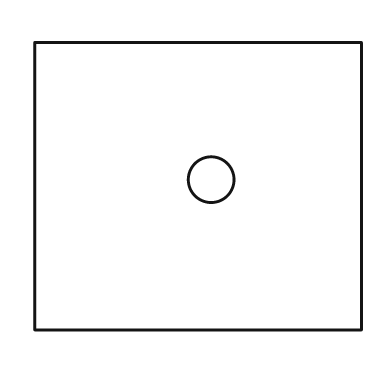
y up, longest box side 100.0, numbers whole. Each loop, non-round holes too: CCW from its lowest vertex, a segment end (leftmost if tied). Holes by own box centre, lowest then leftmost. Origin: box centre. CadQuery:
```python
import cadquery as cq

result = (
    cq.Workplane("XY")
    .moveTo(-50.0, -44.0)
    .lineTo(50.0, -44.0)
    .lineTo(50.0, 44.0)
    .lineTo(-50.0, 44.0)
    .close()
    .moveTo(4.0, 2.0)
    .circle(7.0)
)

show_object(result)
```